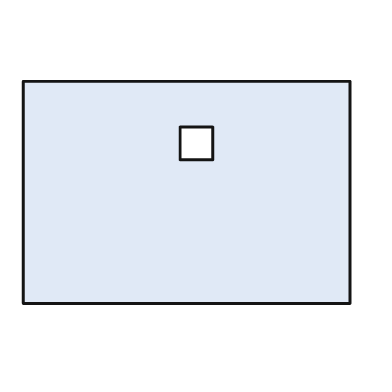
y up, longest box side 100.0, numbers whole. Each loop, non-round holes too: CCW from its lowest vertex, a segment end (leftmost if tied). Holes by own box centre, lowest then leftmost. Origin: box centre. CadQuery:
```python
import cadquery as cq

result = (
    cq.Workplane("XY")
    .moveTo(-50.0, -34.0)
    .lineTo(50.0, -34.0)
    .lineTo(50.0, 34.0)
    .lineTo(-50.0, 34.0)
    .close()
    .moveTo(-2.0, 10.0)
    .lineTo(8.0, 10.0)
    .lineTo(8.0, 20.0)
    .lineTo(-2.0, 20.0)
    .close()
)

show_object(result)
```